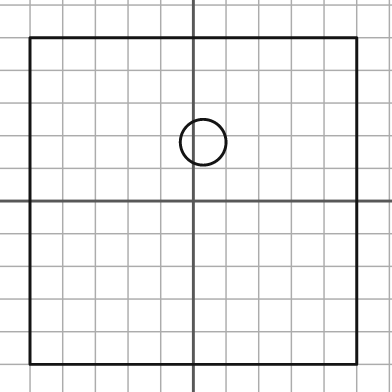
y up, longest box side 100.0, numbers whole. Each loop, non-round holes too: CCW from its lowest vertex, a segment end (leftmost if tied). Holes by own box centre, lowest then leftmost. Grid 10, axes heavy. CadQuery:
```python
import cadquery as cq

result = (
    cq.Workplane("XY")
    .moveTo(-50.0, -50.0)
    .lineTo(50.0, -50.0)
    .lineTo(50.0, 50.0)
    .lineTo(-50.0, 50.0)
    .close()
    .moveTo(3.0, 18.0)
    .circle(7.0)
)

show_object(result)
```